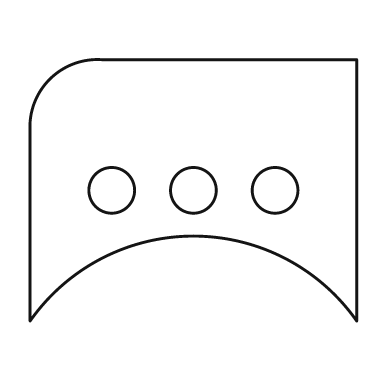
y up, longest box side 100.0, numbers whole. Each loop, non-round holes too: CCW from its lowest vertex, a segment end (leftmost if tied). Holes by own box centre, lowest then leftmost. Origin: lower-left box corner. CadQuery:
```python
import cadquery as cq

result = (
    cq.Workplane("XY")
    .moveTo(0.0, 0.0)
    .threePointArc((50.0, 26.0), (100.0, 0.0))
    .lineTo(100.0, 80.0)
    .lineTo(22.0, 80.0)
    .threePointArc((6.0, 74.0), (0.0, 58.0))
    .close()
    .moveTo(25.0, 40.0)
    .circle(7.0)
    .moveTo(50.0, 40.0)
    .circle(7.0)
    .moveTo(75.0, 40.0)
    .circle(7.0)
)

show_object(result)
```